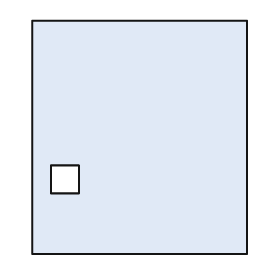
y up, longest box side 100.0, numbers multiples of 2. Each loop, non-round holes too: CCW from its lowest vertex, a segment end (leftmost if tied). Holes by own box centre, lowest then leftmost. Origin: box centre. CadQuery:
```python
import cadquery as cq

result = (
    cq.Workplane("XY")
    .moveTo(-46.0, -50.0)
    .lineTo(46.0, -50.0)
    .lineTo(46.0, 50.0)
    .lineTo(-46.0, 50.0)
    .close()
    .moveTo(-38.0, -24.0)
    .lineTo(-26.0, -24.0)
    .lineTo(-26.0, -12.0)
    .lineTo(-38.0, -12.0)
    .close()
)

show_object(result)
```